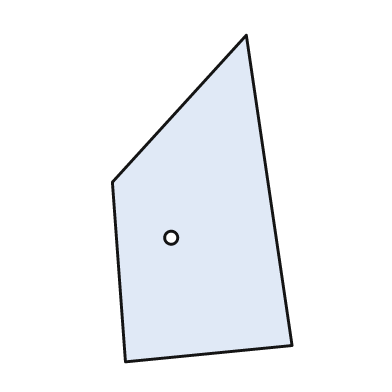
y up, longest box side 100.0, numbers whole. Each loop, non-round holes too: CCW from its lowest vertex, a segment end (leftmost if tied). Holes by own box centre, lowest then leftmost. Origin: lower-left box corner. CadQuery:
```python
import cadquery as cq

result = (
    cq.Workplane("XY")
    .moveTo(4.0, 0.0)
    .lineTo(55.0, 5.0)
    .lineTo(41.0, 100.0)
    .lineTo(0.0, 55.0)
    .close()
    .moveTo(18.0, 38.0)
    .circle(2.0)
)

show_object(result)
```